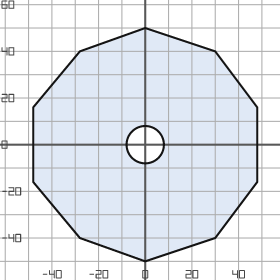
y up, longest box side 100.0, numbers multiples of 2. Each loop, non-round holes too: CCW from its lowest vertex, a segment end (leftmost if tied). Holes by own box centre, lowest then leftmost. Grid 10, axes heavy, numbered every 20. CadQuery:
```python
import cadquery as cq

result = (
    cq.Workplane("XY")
    .moveTo(0.0, -50.0)
    .lineTo(30.0, -40.0)
    .lineTo(48.0, -16.0)
    .lineTo(48.0, 16.0)
    .lineTo(30.0, 40.0)
    .lineTo(0.0, 50.0)
    .lineTo(-28.0, 40.0)
    .lineTo(-48.0, 16.0)
    .lineTo(-48.0, -16.0)
    .lineTo(-28.0, -40.0)
    .close()
    .moveTo(0.0, 0.0)
    .circle(8.0)
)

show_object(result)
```